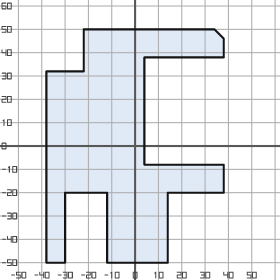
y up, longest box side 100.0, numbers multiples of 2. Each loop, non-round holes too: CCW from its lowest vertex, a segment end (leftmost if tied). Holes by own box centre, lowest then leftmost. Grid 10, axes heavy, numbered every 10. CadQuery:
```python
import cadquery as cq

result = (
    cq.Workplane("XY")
    .moveTo(-38.0, -50.0)
    .lineTo(-30.0, -50.0)
    .lineTo(-30.0, -20.0)
    .lineTo(-12.0, -20.0)
    .lineTo(-12.0, -50.0)
    .lineTo(14.0, -50.0)
    .lineTo(14.0, -20.0)
    .lineTo(38.0, -20.0)
    .lineTo(38.0, -8.0)
    .lineTo(4.0, -8.0)
    .lineTo(4.0, 38.0)
    .lineTo(38.0, 38.0)
    .lineTo(38.0, 46.0)
    .lineTo(34.0, 50.0)
    .lineTo(-22.0, 50.0)
    .lineTo(-22.0, 32.0)
    .lineTo(-38.0, 32.0)
    .close()
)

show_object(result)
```